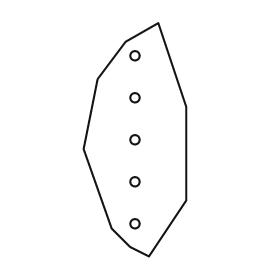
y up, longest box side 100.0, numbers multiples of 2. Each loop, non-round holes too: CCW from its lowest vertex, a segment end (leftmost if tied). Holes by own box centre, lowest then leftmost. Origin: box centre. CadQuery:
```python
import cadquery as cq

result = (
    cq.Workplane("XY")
    .moveTo(6.0, -50.0)
    .lineTo(22.0, -26.0)
    .lineTo(22.0, 14.0)
    .lineTo(10.0, 50.0)
    .lineTo(-4.0, 42.0)
    .lineTo(-16.0, 26.0)
    .lineTo(-22.0, -4.0)
    .lineTo(-10.0, -38.0)
    .lineTo(-2.0, -46.0)
    .close()
    .moveTo(0.0, -36.0)
    .circle(2.0)
    .moveTo(0.0, -18.0)
    .circle(2.0)
    .moveTo(0.0, 0.0)
    .circle(2.0)
    .moveTo(0.0, 18.0)
    .circle(2.0)
    .moveTo(0.0, 36.0)
    .circle(2.0)
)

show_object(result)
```